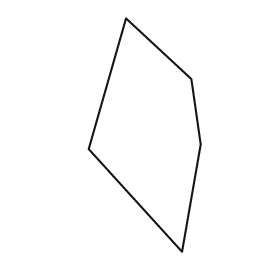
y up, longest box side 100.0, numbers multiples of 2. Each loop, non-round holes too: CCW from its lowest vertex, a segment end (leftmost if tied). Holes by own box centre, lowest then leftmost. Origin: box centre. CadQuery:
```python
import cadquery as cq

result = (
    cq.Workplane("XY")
    .moveTo(16.0, -50.0)
    .lineTo(24.0, -4.0)
    .lineTo(20.0, 24.0)
    .lineTo(-8.0, 50.0)
    .lineTo(-24.0, -6.0)
    .close()
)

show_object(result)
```